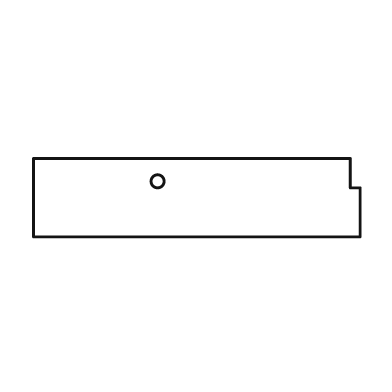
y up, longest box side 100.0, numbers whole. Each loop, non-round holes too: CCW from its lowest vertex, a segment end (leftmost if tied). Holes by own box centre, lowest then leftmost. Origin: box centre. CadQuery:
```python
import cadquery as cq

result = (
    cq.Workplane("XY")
    .moveTo(-50.0, -12.0)
    .lineTo(50.0, -12.0)
    .lineTo(50.0, 3.0)
    .lineTo(47.0, 3.0)
    .lineTo(47.0, 12.0)
    .lineTo(-50.0, 12.0)
    .close()
    .moveTo(-12.0, 5.0)
    .circle(2.0)
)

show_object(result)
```